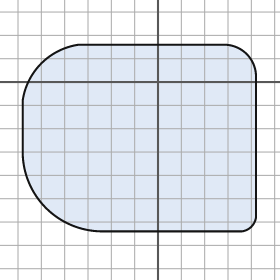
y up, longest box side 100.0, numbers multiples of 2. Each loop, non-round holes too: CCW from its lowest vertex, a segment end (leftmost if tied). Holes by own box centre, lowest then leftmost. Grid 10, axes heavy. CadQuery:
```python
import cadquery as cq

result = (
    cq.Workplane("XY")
    .moveTo(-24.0, -64.0)
    .lineTo(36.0, -64.0)
    .threePointArc((40.0, -62.0), (42.0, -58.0))
    .lineTo(42.0, 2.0)
    .threePointArc((38.0, 12.0), (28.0, 16.0))
    .lineTo(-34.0, 16.0)
    .threePointArc((-50.0, 8.0), (-58.0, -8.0))
    .lineTo(-58.0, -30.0)
    .threePointArc((-48.0, -54.0), (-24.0, -64.0))
    .close()
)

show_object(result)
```